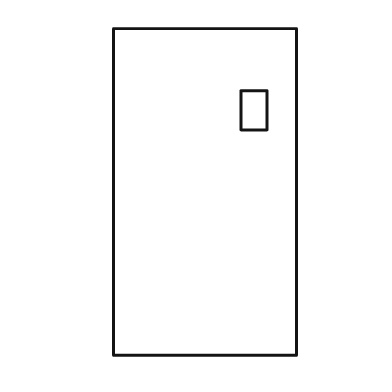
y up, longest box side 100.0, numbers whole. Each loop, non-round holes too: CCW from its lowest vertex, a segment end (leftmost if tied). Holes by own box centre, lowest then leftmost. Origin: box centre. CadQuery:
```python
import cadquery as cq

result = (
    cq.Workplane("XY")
    .moveTo(-28.0, -50.0)
    .lineTo(28.0, -50.0)
    .lineTo(28.0, 50.0)
    .lineTo(-28.0, 50.0)
    .close()
    .moveTo(11.0, 19.0)
    .lineTo(19.0, 19.0)
    .lineTo(19.0, 31.0)
    .lineTo(11.0, 31.0)
    .close()
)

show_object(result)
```